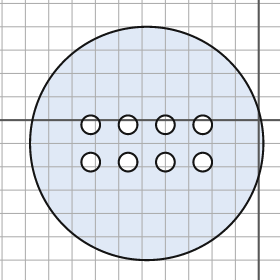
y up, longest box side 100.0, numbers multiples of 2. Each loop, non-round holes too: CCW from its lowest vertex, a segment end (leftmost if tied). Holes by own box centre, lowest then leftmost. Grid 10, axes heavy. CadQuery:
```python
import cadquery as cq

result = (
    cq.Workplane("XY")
    .moveTo(-48.0, -10.0)
    .circle(50.0)
    .moveTo(-72.0, -18.0)
    .circle(4.0)
    .moveTo(-56.0, -18.0)
    .circle(4.0)
    .moveTo(-40.0, -18.0)
    .circle(4.0)
    .moveTo(-24.0, -18.0)
    .circle(4.0)
    .moveTo(-72.0, -2.0)
    .circle(4.0)
    .moveTo(-56.0, -2.0)
    .circle(4.0)
    .moveTo(-40.0, -2.0)
    .circle(4.0)
    .moveTo(-24.0, -2.0)
    .circle(4.0)
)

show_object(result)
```